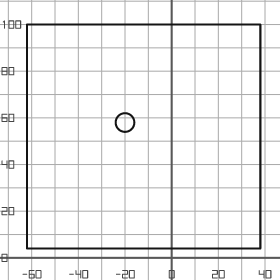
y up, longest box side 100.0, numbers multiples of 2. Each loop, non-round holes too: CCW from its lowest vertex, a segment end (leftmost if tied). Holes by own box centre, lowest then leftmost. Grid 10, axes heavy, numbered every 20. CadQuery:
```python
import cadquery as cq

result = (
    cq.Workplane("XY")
    .moveTo(-62.0, 4.0)
    .lineTo(38.0, 4.0)
    .lineTo(38.0, 100.0)
    .lineTo(-62.0, 100.0)
    .close()
    .moveTo(-20.0, 58.0)
    .circle(4.0)
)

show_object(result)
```